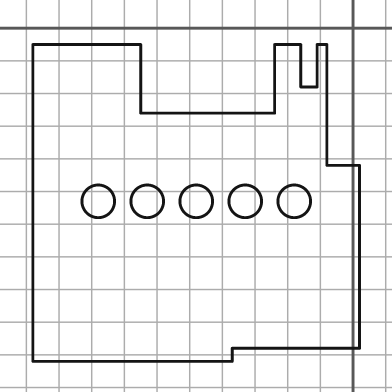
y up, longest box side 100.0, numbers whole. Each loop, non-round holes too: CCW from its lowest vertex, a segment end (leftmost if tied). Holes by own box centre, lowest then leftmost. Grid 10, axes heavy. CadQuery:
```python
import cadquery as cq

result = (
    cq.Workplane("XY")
    .moveTo(-98.0, -102.0)
    .lineTo(-37.0, -102.0)
    .lineTo(-37.0, -98.0)
    .lineTo(2.0, -98.0)
    .lineTo(2.0, -42.0)
    .lineTo(-8.0, -42.0)
    .lineTo(-8.0, -5.0)
    .lineTo(-11.0, -5.0)
    .lineTo(-11.0, -18.0)
    .lineTo(-16.0, -18.0)
    .lineTo(-16.0, -5.0)
    .lineTo(-24.0, -5.0)
    .lineTo(-24.0, -26.0)
    .lineTo(-65.0, -26.0)
    .lineTo(-65.0, -5.0)
    .lineTo(-98.0, -5.0)
    .close()
    .moveTo(-78.0, -53.0)
    .circle(5.0)
    .moveTo(-63.0, -53.0)
    .circle(5.0)
    .moveTo(-48.0, -53.0)
    .circle(5.0)
    .moveTo(-33.0, -53.0)
    .circle(5.0)
    .moveTo(-18.0, -53.0)
    .circle(5.0)
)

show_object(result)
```